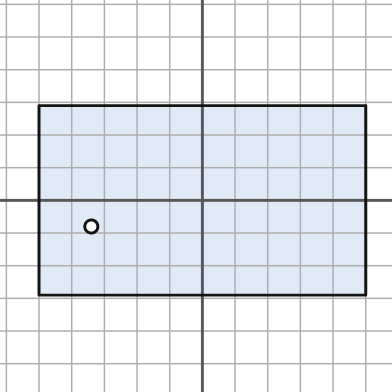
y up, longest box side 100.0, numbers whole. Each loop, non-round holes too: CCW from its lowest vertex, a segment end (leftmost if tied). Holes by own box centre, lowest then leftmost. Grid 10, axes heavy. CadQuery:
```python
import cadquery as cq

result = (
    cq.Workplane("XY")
    .moveTo(-50.0, -29.0)
    .lineTo(50.0, -29.0)
    .lineTo(50.0, 29.0)
    .lineTo(-50.0, 29.0)
    .close()
    .moveTo(-34.0, -8.0)
    .circle(2.0)
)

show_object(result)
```